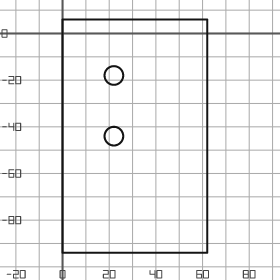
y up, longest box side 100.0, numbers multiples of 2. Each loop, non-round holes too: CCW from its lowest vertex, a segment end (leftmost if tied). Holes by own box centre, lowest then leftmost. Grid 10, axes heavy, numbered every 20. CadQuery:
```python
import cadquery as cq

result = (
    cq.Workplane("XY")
    .moveTo(0.0, -94.0)
    .lineTo(62.0, -94.0)
    .lineTo(62.0, 6.0)
    .lineTo(0.0, 6.0)
    .close()
    .moveTo(22.0, -44.0)
    .circle(4.0)
    .moveTo(22.0, -18.0)
    .circle(4.0)
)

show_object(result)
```